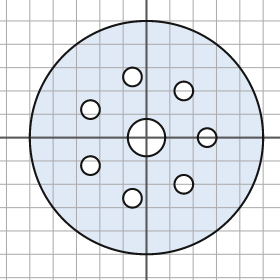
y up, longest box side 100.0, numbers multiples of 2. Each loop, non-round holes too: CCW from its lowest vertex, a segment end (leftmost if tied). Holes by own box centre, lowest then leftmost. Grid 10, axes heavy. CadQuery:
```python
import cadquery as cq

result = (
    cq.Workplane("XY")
    .moveTo(0.0, 0.0)
    .circle(50.0)
    .moveTo(-6.0, -26.0)
    .circle(4.0)
    .moveTo(16.0, -20.0)
    .circle(4.0)
    .moveTo(-24.0, -12.0)
    .circle(4.0)
    .moveTo(0.0, 0.0)
    .circle(8.0)
    .moveTo(26.0, 0.0)
    .circle(4.0)
    .moveTo(-24.0, 12.0)
    .circle(4.0)
    .moveTo(16.0, 20.0)
    .circle(4.0)
    .moveTo(-6.0, 26.0)
    .circle(4.0)
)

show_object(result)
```